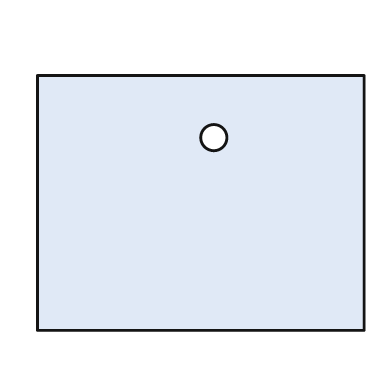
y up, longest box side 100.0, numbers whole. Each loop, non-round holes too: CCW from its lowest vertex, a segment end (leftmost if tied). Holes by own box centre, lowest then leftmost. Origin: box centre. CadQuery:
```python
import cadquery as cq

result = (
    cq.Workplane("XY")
    .moveTo(-50.0, -39.0)
    .lineTo(50.0, -39.0)
    .lineTo(50.0, 39.0)
    .lineTo(-50.0, 39.0)
    .close()
    .moveTo(4.0, 20.0)
    .circle(4.0)
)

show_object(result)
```